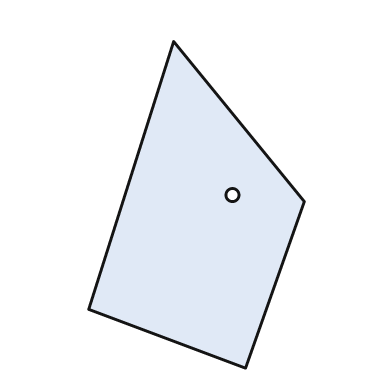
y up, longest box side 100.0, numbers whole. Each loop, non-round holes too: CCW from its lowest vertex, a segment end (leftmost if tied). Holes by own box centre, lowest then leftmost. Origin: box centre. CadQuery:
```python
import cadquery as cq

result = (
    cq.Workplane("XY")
    .moveTo(15.0, -50.0)
    .lineTo(33.0, 1.0)
    .lineTo(-7.0, 50.0)
    .lineTo(-33.0, -32.0)
    .close()
    .moveTo(11.0, 3.0)
    .circle(2.0)
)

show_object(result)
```